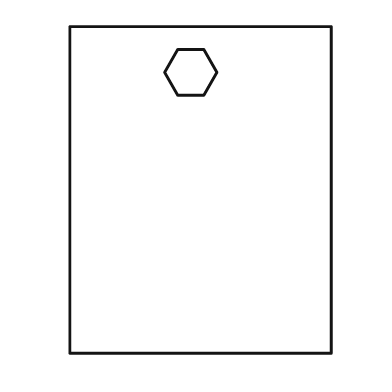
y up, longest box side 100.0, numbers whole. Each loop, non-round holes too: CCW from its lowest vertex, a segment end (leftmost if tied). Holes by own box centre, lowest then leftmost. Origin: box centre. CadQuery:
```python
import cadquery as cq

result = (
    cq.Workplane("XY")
    .moveTo(-40.0, -50.0)
    .lineTo(40.0, -50.0)
    .lineTo(40.0, 50.0)
    .lineTo(-40.0, 50.0)
    .close()
    .moveTo(-7.0, 29.0)
    .lineTo(1.0, 29.0)
    .lineTo(5.0, 36.0)
    .lineTo(1.0, 43.0)
    .lineTo(-7.0, 43.0)
    .lineTo(-11.0, 36.0)
    .close()
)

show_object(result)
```